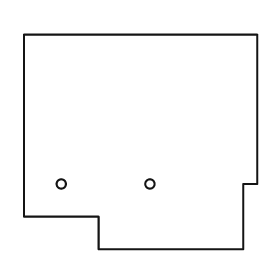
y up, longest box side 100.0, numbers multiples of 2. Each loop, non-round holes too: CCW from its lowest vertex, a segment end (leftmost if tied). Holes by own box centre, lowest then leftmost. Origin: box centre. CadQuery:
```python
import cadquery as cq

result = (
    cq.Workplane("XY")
    .moveTo(-18.0, -46.0)
    .lineTo(44.0, -46.0)
    .lineTo(44.0, -18.0)
    .lineTo(50.0, -18.0)
    .lineTo(50.0, 46.0)
    .lineTo(-50.0, 46.0)
    .lineTo(-50.0, -32.0)
    .lineTo(-18.0, -32.0)
    .close()
    .moveTo(-34.0, -18.0)
    .circle(2.0)
    .moveTo(4.0, -18.0)
    .circle(2.0)
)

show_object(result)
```